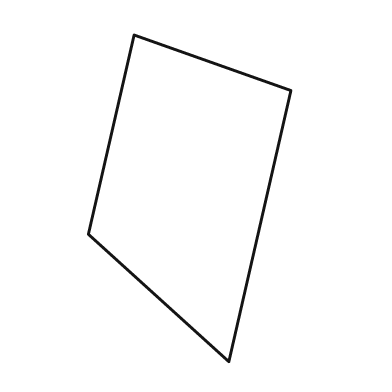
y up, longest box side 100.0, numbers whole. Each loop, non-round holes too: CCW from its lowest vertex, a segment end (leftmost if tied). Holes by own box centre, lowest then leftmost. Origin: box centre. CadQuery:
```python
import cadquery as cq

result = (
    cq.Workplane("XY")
    .moveTo(12.0, -50.0)
    .lineTo(31.0, 33.0)
    .lineTo(-17.0, 50.0)
    .lineTo(-31.0, -11.0)
    .close()
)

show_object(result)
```